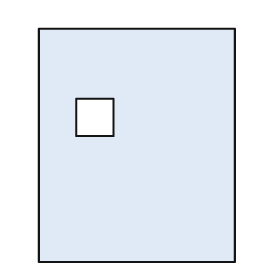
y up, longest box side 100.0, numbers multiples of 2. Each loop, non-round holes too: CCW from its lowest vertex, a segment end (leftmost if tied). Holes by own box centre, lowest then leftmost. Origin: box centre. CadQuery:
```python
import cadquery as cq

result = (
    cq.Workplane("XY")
    .moveTo(-42.0, -50.0)
    .lineTo(42.0, -50.0)
    .lineTo(42.0, 50.0)
    .lineTo(-42.0, 50.0)
    .close()
    .moveTo(-26.0, 4.0)
    .lineTo(-10.0, 4.0)
    .lineTo(-10.0, 20.0)
    .lineTo(-26.0, 20.0)
    .close()
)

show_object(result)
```